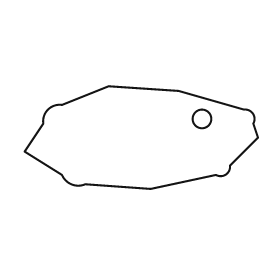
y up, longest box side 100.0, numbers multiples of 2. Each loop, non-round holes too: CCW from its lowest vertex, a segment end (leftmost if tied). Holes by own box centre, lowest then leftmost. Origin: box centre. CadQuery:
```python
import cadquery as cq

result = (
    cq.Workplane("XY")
    .moveTo(4.0, -22.0)
    .lineTo(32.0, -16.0)
    .threePointArc((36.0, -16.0), (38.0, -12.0))
    .lineTo(50.0, 0.0)
    .lineTo(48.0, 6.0)
    .threePointArc((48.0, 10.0), (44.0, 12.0))
    .lineTo(16.0, 20.0)
    .lineTo(-14.0, 22.0)
    .lineTo(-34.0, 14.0)
    .threePointArc((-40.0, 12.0), (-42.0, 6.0))
    .lineTo(-50.0, -6.0)
    .lineTo(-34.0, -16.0)
    .threePointArc((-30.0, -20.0), (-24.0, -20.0))
    .close()
    .moveTo(26.0, 8.0)
    .circle(4.0)
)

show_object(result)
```